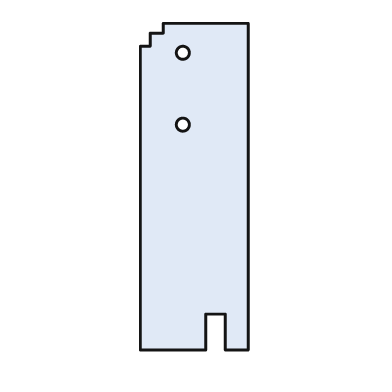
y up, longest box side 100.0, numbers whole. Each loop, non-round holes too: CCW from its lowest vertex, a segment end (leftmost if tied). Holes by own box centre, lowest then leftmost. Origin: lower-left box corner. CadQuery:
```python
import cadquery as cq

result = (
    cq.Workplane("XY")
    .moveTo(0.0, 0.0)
    .lineTo(20.0, 0.0)
    .lineTo(20.0, 11.0)
    .lineTo(26.0, 11.0)
    .lineTo(26.0, 0.0)
    .lineTo(33.0, 0.0)
    .lineTo(33.0, 100.0)
    .lineTo(7.0, 100.0)
    .lineTo(7.0, 97.0)
    .lineTo(3.0, 97.0)
    .lineTo(3.0, 93.0)
    .lineTo(0.0, 93.0)
    .close()
    .moveTo(13.0, 69.0)
    .circle(2.0)
    .moveTo(13.0, 91.0)
    .circle(2.0)
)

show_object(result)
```